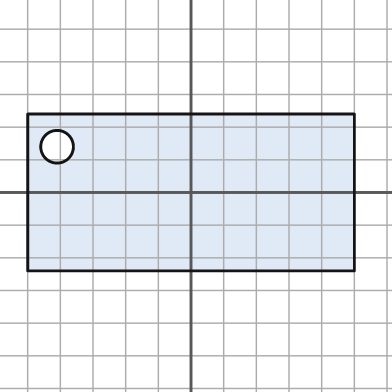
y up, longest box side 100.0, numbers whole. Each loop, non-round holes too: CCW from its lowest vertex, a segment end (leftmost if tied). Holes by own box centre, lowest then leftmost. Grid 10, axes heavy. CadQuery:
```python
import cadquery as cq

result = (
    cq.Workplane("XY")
    .moveTo(-50.0, -24.0)
    .lineTo(50.0, -24.0)
    .lineTo(50.0, 24.0)
    .lineTo(-50.0, 24.0)
    .close()
    .moveTo(-41.0, 14.0)
    .circle(5.0)
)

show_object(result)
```